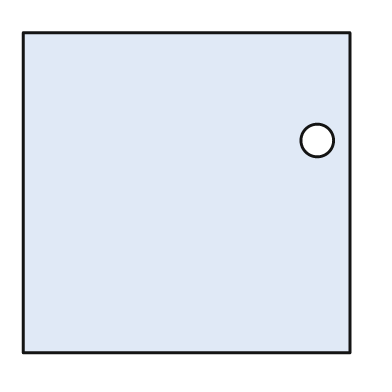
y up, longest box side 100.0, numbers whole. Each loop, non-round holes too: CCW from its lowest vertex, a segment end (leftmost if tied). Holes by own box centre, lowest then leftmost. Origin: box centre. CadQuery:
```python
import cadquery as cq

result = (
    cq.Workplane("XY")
    .moveTo(-50.0, -49.0)
    .lineTo(50.0, -49.0)
    .lineTo(50.0, 49.0)
    .lineTo(-50.0, 49.0)
    .close()
    .moveTo(40.0, 16.0)
    .circle(5.0)
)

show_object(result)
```